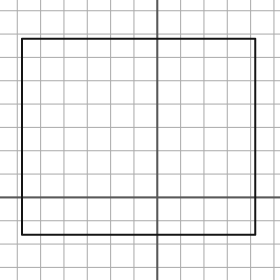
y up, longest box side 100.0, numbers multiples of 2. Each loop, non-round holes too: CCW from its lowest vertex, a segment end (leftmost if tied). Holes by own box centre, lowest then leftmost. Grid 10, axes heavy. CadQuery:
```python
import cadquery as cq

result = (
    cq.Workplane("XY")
    .moveTo(-58.0, -16.0)
    .lineTo(42.0, -16.0)
    .lineTo(42.0, 68.0)
    .lineTo(-58.0, 68.0)
    .close()
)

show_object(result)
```